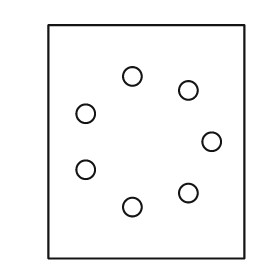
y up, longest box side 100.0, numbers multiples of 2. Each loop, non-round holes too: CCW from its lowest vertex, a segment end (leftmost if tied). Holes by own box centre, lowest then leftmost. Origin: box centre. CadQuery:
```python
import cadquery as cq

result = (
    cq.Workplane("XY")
    .moveTo(-42.0, -50.0)
    .lineTo(42.0, -50.0)
    .lineTo(42.0, 50.0)
    .lineTo(-42.0, 50.0)
    .close()
    .moveTo(-6.0, -28.0)
    .circle(4.0)
    .moveTo(18.0, -22.0)
    .circle(4.0)
    .moveTo(-26.0, -12.0)
    .circle(4.0)
    .moveTo(28.0, 0.0)
    .circle(4.0)
    .moveTo(-26.0, 12.0)
    .circle(4.0)
    .moveTo(18.0, 22.0)
    .circle(4.0)
    .moveTo(-6.0, 28.0)
    .circle(4.0)
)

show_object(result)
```